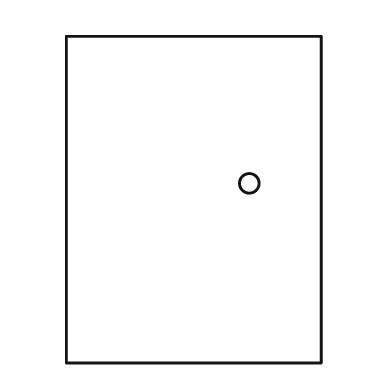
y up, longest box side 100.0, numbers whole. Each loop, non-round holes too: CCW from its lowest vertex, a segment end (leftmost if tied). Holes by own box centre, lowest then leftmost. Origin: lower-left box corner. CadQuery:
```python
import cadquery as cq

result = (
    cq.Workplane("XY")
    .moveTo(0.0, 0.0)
    .lineTo(78.0, 0.0)
    .lineTo(78.0, 100.0)
    .lineTo(0.0, 100.0)
    .close()
    .moveTo(56.0, 55.0)
    .circle(3.0)
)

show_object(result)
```